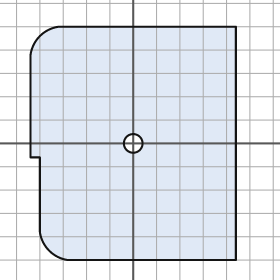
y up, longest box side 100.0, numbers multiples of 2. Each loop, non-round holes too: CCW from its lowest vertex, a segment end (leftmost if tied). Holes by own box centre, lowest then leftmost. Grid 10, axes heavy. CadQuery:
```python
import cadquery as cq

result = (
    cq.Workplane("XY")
    .moveTo(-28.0, -50.0)
    .lineTo(44.0, -50.0)
    .lineTo(44.0, 50.0)
    .lineTo(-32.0, 50.0)
    .threePointArc((-40.0, 46.0), (-44.0, 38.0))
    .lineTo(-44.0, -6.0)
    .lineTo(-40.0, -6.0)
    .lineTo(-40.0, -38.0)
    .threePointArc((-36.0, -46.0), (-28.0, -50.0))
    .close()
    .moveTo(0.0, 0.0)
    .circle(4.0)
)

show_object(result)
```